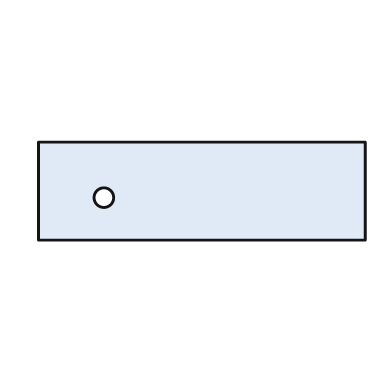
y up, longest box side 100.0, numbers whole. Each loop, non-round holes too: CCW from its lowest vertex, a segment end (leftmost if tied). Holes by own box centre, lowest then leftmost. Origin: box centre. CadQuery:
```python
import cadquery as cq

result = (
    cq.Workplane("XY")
    .moveTo(-50.0, -15.0)
    .lineTo(50.0, -15.0)
    .lineTo(50.0, 15.0)
    .lineTo(-50.0, 15.0)
    .close()
    .moveTo(-30.0, -2.0)
    .circle(3.0)
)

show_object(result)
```